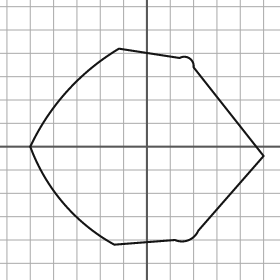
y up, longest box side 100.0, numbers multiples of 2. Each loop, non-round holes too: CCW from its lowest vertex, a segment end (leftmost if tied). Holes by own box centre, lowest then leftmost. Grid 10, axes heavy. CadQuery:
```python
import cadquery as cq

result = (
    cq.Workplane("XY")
    .moveTo(-14.0, -42.0)
    .lineTo(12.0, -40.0)
    .threePointArc((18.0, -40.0), (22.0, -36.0))
    .lineTo(50.0, -4.0)
    .lineTo(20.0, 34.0)
    .threePointArc((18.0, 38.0), (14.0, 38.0))
    .lineTo(-12.0, 42.0)
    .threePointArc((-34.0, 24.0), (-50.0, 0.0))
    .threePointArc((-36.0, -24.0), (-14.0, -42.0))
    .close()
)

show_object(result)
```